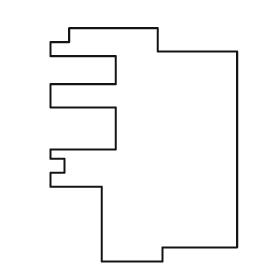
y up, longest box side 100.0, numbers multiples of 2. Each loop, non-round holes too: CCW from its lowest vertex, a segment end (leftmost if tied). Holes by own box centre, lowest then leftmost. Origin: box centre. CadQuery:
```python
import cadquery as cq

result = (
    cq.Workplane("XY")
    .moveTo(-18.0, -50.0)
    .lineTo(8.0, -50.0)
    .lineTo(8.0, -44.0)
    .lineTo(40.0, -44.0)
    .lineTo(40.0, 40.0)
    .lineTo(6.0, 40.0)
    .lineTo(6.0, 50.0)
    .lineTo(-32.0, 50.0)
    .lineTo(-32.0, 44.0)
    .lineTo(-40.0, 44.0)
    .lineTo(-40.0, 38.0)
    .lineTo(-12.0, 38.0)
    .lineTo(-12.0, 26.0)
    .lineTo(-40.0, 26.0)
    .lineTo(-40.0, 16.0)
    .lineTo(-12.0, 16.0)
    .lineTo(-12.0, -2.0)
    .lineTo(-40.0, -2.0)
    .lineTo(-40.0, -6.0)
    .lineTo(-34.0, -6.0)
    .lineTo(-34.0, -12.0)
    .lineTo(-40.0, -12.0)
    .lineTo(-40.0, -18.0)
    .lineTo(-18.0, -18.0)
    .close()
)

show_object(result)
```